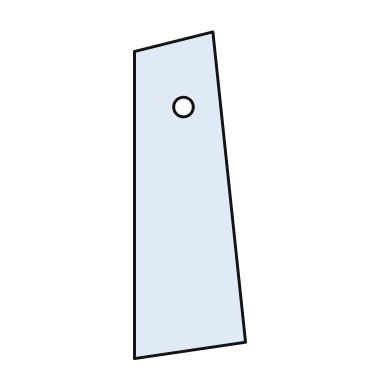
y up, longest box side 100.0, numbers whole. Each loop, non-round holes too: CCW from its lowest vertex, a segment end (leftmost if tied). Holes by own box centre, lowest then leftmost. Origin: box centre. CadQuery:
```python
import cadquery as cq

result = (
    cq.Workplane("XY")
    .moveTo(-17.0, -50.0)
    .lineTo(17.0, -45.0)
    .lineTo(7.0, 50.0)
    .lineTo(-17.0, 44.0)
    .close()
    .moveTo(-2.0, 27.0)
    .circle(3.0)
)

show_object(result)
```